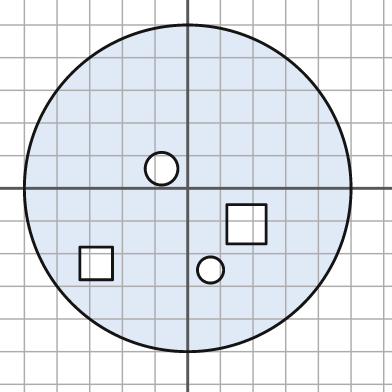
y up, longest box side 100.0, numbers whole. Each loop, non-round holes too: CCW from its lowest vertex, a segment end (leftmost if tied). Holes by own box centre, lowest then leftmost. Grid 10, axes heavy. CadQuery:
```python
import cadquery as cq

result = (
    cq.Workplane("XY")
    .moveTo(0.0, 0.0)
    .circle(50.0)
    .moveTo(7.0, -25.0)
    .circle(4.0)
    .moveTo(-33.0, -28.0)
    .lineTo(-23.0, -28.0)
    .lineTo(-23.0, -18.0)
    .lineTo(-33.0, -18.0)
    .close()
    .moveTo(12.0, -17.0)
    .lineTo(24.0, -17.0)
    .lineTo(24.0, -5.0)
    .lineTo(12.0, -5.0)
    .close()
    .moveTo(-8.0, 6.0)
    .circle(5.0)
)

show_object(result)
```